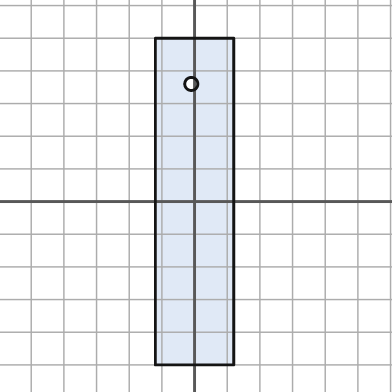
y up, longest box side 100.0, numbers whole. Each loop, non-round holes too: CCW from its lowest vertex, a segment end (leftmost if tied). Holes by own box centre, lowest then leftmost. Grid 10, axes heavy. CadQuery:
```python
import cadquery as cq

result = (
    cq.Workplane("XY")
    .moveTo(-12.0, -50.0)
    .lineTo(12.0, -50.0)
    .lineTo(12.0, 50.0)
    .lineTo(-12.0, 50.0)
    .close()
    .moveTo(-1.0, 36.0)
    .circle(2.0)
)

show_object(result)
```